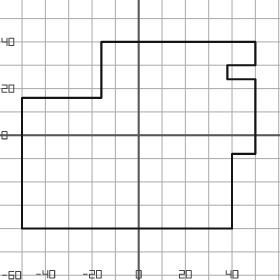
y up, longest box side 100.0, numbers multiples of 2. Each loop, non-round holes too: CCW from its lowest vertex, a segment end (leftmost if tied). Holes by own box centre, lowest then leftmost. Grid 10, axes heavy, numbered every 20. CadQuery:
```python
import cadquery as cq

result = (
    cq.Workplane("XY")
    .moveTo(-50.0, -40.0)
    .lineTo(40.0, -40.0)
    .lineTo(40.0, -8.0)
    .lineTo(50.0, -8.0)
    .lineTo(50.0, 24.0)
    .lineTo(38.0, 24.0)
    .lineTo(38.0, 30.0)
    .lineTo(50.0, 30.0)
    .lineTo(50.0, 40.0)
    .lineTo(-16.0, 40.0)
    .lineTo(-16.0, 16.0)
    .lineTo(-50.0, 16.0)
    .close()
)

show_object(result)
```